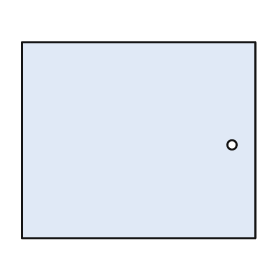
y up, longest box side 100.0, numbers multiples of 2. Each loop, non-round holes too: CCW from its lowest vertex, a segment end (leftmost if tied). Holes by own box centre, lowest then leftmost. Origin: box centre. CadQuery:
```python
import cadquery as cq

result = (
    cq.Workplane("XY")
    .moveTo(-50.0, -42.0)
    .lineTo(50.0, -42.0)
    .lineTo(50.0, 42.0)
    .lineTo(-50.0, 42.0)
    .close()
    .moveTo(40.0, -2.0)
    .circle(2.0)
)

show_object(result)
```